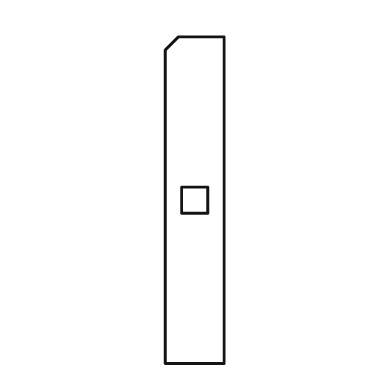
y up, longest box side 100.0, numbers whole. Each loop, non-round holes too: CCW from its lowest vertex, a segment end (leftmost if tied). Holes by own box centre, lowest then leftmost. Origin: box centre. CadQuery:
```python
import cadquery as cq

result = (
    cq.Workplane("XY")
    .moveTo(-9.0, -50.0)
    .lineTo(9.0, -50.0)
    .lineTo(9.0, 50.0)
    .lineTo(-5.0, 50.0)
    .lineTo(-9.0, 46.0)
    .close()
    .moveTo(-4.0, -4.0)
    .lineTo(4.0, -4.0)
    .lineTo(4.0, 4.0)
    .lineTo(-4.0, 4.0)
    .close()
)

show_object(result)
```